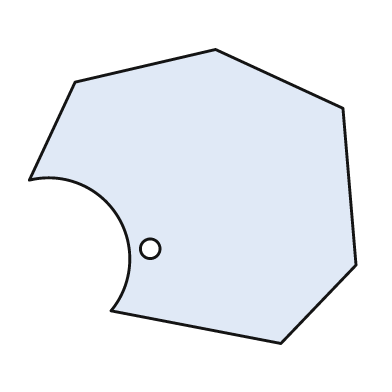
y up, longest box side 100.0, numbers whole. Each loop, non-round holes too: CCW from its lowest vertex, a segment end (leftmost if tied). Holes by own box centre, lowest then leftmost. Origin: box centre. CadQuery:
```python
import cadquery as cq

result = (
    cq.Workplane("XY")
    .moveTo(27.0, -45.0)
    .lineTo(50.0, -21.0)
    .lineTo(46.0, 27.0)
    .lineTo(7.0, 45.0)
    .lineTo(-36.0, 35.0)
    .lineTo(-50.0, 5.0)
    .threePointArc((-23.0, -6.0), (-25.0, -35.0))
    .close()
    .moveTo(-13.0, -16.0)
    .circle(3.0)
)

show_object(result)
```